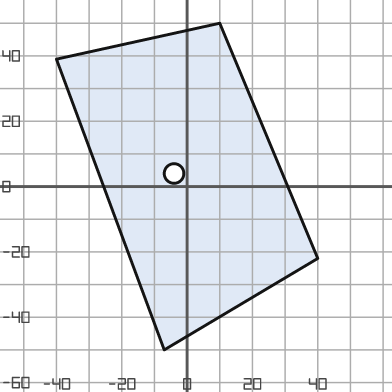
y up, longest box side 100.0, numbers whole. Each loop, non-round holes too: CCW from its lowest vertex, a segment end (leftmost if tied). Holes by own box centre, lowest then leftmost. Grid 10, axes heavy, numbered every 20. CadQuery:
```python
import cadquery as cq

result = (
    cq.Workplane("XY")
    .moveTo(-7.0, -50.0)
    .lineTo(40.0, -22.0)
    .lineTo(10.0, 50.0)
    .lineTo(-40.0, 39.0)
    .close()
    .moveTo(-4.0, 4.0)
    .circle(3.0)
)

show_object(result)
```